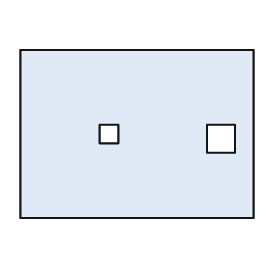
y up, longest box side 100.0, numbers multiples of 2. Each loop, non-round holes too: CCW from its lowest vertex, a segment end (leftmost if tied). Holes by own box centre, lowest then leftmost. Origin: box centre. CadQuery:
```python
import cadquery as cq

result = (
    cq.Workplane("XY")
    .moveTo(-50.0, -36.0)
    .lineTo(50.0, -36.0)
    .lineTo(50.0, 36.0)
    .lineTo(-50.0, 36.0)
    .close()
    .moveTo(30.0, -8.0)
    .lineTo(42.0, -8.0)
    .lineTo(42.0, 4.0)
    .lineTo(30.0, 4.0)
    .close()
    .moveTo(-16.0, -4.0)
    .lineTo(-8.0, -4.0)
    .lineTo(-8.0, 4.0)
    .lineTo(-16.0, 4.0)
    .close()
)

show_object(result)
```